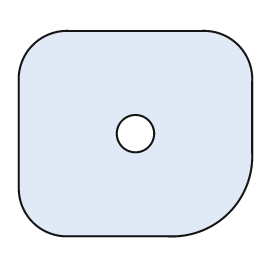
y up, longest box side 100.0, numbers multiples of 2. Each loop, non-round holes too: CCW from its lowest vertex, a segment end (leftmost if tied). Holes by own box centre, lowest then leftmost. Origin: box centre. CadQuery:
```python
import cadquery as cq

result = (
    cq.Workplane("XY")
    .moveTo(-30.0, -44.0)
    .lineTo(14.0, -44.0)
    .threePointArc((40.0, -34.0), (50.0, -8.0))
    .lineTo(50.0, 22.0)
    .threePointArc((44.0, 38.0), (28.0, 44.0))
    .lineTo(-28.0, 44.0)
    .threePointArc((-44.0, 38.0), (-50.0, 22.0))
    .lineTo(-50.0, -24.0)
    .threePointArc((-44.0, -38.0), (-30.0, -44.0))
    .close()
    .moveTo(0.0, 0.0)
    .circle(8.0)
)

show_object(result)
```